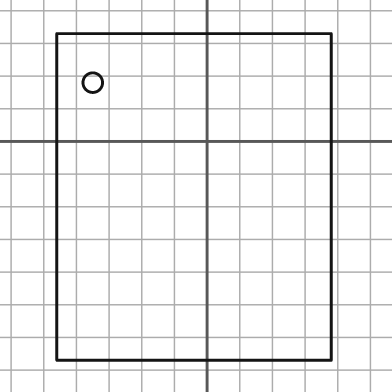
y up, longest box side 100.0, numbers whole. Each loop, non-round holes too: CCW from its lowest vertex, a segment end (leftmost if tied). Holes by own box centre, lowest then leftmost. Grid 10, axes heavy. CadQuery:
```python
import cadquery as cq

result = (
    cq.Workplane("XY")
    .moveTo(-46.0, -67.0)
    .lineTo(38.0, -67.0)
    .lineTo(38.0, 33.0)
    .lineTo(-46.0, 33.0)
    .close()
    .moveTo(-35.0, 18.0)
    .circle(3.0)
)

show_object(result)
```